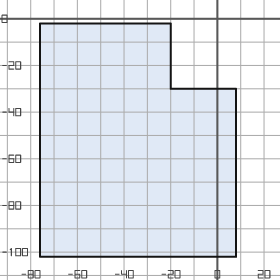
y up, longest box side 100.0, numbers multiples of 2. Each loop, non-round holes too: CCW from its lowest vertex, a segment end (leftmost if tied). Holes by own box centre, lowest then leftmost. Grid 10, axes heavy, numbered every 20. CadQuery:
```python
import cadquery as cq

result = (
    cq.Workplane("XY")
    .moveTo(-76.0, -102.0)
    .lineTo(8.0, -102.0)
    .lineTo(8.0, -30.0)
    .lineTo(-20.0, -30.0)
    .lineTo(-20.0, -2.0)
    .lineTo(-76.0, -2.0)
    .close()
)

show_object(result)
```